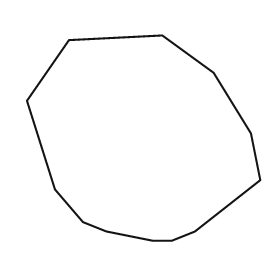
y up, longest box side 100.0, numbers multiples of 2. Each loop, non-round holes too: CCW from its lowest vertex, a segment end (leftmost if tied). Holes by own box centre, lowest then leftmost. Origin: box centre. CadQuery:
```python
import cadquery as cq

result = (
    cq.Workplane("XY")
    .moveTo(4.0, -44.0)
    .lineTo(12.0, -44.0)
    .lineTo(22.0, -40.0)
    .lineTo(50.0, -18.0)
    .lineTo(46.0, 2.0)
    .lineTo(30.0, 28.0)
    .lineTo(8.0, 44.0)
    .lineTo(-32.0, 42.0)
    .lineTo(-50.0, 16.0)
    .lineTo(-38.0, -22.0)
    .lineTo(-26.0, -36.0)
    .lineTo(-16.0, -40.0)
    .close()
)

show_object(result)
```